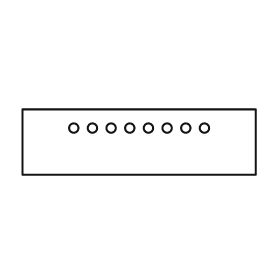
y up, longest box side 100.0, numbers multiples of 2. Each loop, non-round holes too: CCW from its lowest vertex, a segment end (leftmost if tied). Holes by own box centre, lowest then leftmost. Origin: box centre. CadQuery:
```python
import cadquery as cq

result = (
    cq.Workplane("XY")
    .moveTo(-50.0, -14.0)
    .lineTo(50.0, -14.0)
    .lineTo(50.0, 14.0)
    .lineTo(-50.0, 14.0)
    .close()
    .moveTo(-28.0, 6.0)
    .circle(2.0)
    .moveTo(-20.0, 6.0)
    .circle(2.0)
    .moveTo(-12.0, 6.0)
    .circle(2.0)
    .moveTo(-4.0, 6.0)
    .circle(2.0)
    .moveTo(4.0, 6.0)
    .circle(2.0)
    .moveTo(12.0, 6.0)
    .circle(2.0)
    .moveTo(20.0, 6.0)
    .circle(2.0)
    .moveTo(28.0, 6.0)
    .circle(2.0)
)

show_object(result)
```